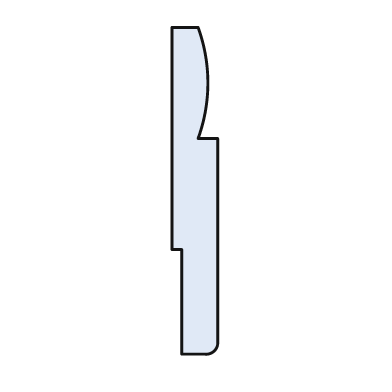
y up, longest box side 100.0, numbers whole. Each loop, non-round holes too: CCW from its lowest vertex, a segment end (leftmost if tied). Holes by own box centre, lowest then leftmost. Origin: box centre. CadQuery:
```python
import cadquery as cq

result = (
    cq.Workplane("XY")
    .moveTo(-4.0, -50.0)
    .lineTo(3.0, -50.0)
    .threePointArc((6.0, -49.0), (7.0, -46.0))
    .lineTo(7.0, 16.0)
    .lineTo(1.0, 16.0)
    .threePointArc((4.0, 33.0), (1.0, 50.0))
    .lineTo(-7.0, 50.0)
    .lineTo(-7.0, -18.0)
    .lineTo(-4.0, -18.0)
    .close()
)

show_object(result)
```